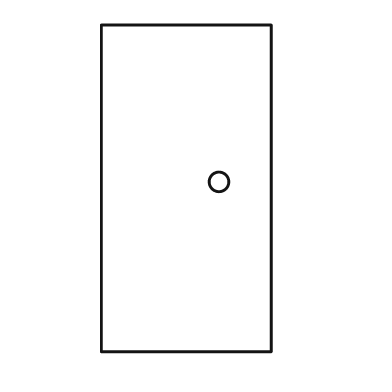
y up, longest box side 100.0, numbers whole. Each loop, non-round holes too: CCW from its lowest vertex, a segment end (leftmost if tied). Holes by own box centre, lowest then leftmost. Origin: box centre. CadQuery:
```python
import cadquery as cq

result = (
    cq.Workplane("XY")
    .moveTo(-26.0, -50.0)
    .lineTo(26.0, -50.0)
    .lineTo(26.0, 50.0)
    .lineTo(-26.0, 50.0)
    .close()
    .moveTo(10.0, 2.0)
    .circle(3.0)
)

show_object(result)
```